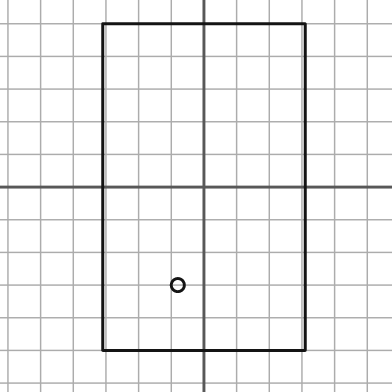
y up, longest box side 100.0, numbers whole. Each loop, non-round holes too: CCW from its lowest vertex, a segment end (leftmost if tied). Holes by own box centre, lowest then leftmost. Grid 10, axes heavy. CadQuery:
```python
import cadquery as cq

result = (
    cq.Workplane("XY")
    .moveTo(-31.0, -50.0)
    .lineTo(31.0, -50.0)
    .lineTo(31.0, 50.0)
    .lineTo(-31.0, 50.0)
    .close()
    .moveTo(-8.0, -30.0)
    .circle(2.0)
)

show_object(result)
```